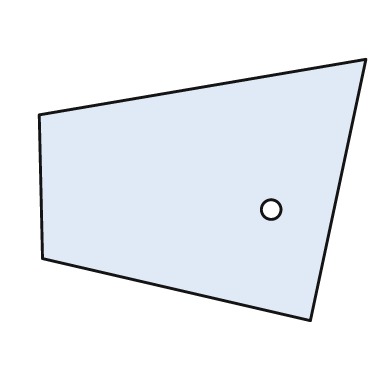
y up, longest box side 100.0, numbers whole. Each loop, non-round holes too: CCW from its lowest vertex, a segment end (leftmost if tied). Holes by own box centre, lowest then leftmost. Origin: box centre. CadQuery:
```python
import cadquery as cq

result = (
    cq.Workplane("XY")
    .moveTo(33.0, -40.0)
    .lineTo(50.0, 40.0)
    .lineTo(-50.0, 23.0)
    .lineTo(-49.0, -21.0)
    .close()
    .moveTo(21.0, -6.0)
    .circle(3.0)
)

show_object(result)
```